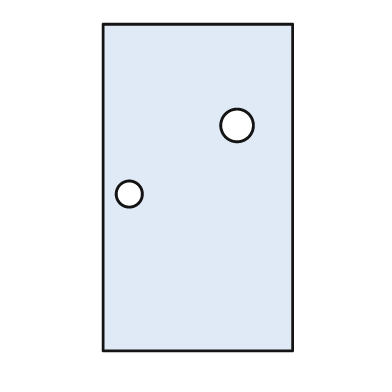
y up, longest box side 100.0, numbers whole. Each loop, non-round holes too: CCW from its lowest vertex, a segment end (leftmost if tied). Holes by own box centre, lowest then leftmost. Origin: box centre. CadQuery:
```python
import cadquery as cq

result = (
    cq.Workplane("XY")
    .moveTo(-29.0, -50.0)
    .lineTo(29.0, -50.0)
    .lineTo(29.0, 50.0)
    .lineTo(-29.0, 50.0)
    .close()
    .moveTo(-21.0, -2.0)
    .circle(4.0)
    .moveTo(12.0, 19.0)
    .circle(5.0)
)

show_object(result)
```